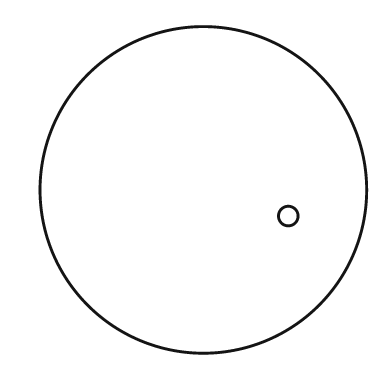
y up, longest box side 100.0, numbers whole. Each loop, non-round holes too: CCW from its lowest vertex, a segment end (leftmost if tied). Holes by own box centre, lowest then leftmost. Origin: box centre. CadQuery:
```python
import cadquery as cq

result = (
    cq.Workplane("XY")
    .moveTo(0.0, 0.0)
    .circle(50.0)
    .moveTo(26.0, -8.0)
    .circle(3.0)
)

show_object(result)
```